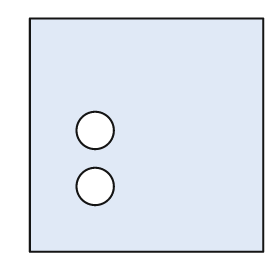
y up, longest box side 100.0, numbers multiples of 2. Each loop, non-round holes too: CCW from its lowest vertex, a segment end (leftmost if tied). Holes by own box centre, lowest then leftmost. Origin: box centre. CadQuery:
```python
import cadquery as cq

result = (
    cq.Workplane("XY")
    .moveTo(-50.0, -50.0)
    .lineTo(50.0, -50.0)
    .lineTo(50.0, 50.0)
    .lineTo(-50.0, 50.0)
    .close()
    .moveTo(-22.0, -22.0)
    .circle(8.0)
    .moveTo(-22.0, 2.0)
    .circle(8.0)
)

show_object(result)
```